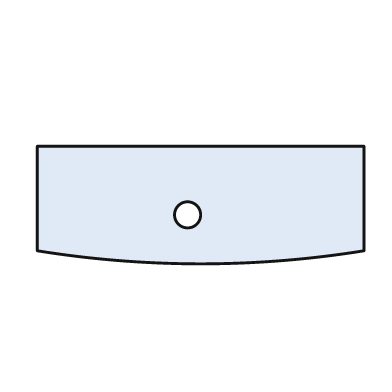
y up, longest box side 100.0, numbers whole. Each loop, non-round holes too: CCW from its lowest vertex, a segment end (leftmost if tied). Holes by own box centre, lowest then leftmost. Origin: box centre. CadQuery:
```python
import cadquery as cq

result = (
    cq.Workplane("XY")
    .moveTo(-50.0, -14.0)
    .threePointArc((0.0, -18.0), (50.0, -14.0))
    .lineTo(50.0, 18.0)
    .lineTo(-50.0, 18.0)
    .close()
    .moveTo(-4.0, -3.0)
    .circle(4.0)
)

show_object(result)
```